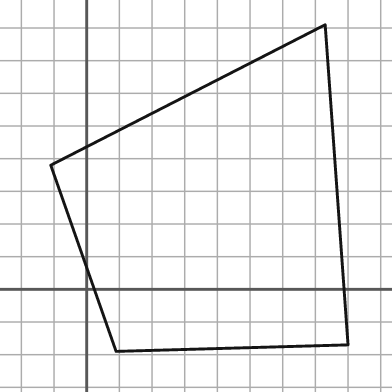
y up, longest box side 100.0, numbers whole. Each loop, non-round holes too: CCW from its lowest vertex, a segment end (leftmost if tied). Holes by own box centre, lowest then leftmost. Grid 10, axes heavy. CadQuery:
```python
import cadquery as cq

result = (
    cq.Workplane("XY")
    .moveTo(9.0, -19.0)
    .lineTo(80.0, -17.0)
    .lineTo(73.0, 81.0)
    .lineTo(-11.0, 38.0)
    .close()
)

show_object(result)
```